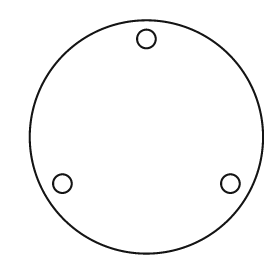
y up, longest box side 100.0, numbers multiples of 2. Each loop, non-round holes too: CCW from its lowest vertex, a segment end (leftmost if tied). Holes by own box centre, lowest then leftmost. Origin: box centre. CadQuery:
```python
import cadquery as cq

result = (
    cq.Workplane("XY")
    .moveTo(0.0, 0.0)
    .circle(50.0)
    .moveTo(-36.0, -20.0)
    .circle(4.0)
    .moveTo(36.0, -20.0)
    .circle(4.0)
    .moveTo(0.0, 42.0)
    .circle(4.0)
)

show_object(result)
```